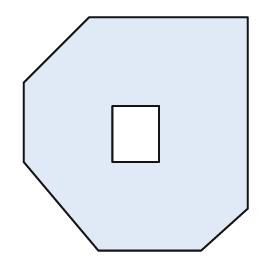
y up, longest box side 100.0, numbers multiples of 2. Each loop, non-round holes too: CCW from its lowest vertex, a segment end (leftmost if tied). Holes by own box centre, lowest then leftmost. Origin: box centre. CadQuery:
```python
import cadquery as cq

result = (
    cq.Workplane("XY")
    .moveTo(-16.0, -50.0)
    .lineTo(28.0, -50.0)
    .lineTo(48.0, -32.0)
    .lineTo(48.0, 50.0)
    .lineTo(-20.0, 50.0)
    .lineTo(-48.0, 22.0)
    .lineTo(-48.0, -12.0)
    .close()
    .moveTo(-10.0, -12.0)
    .lineTo(10.0, -12.0)
    .lineTo(10.0, 12.0)
    .lineTo(-10.0, 12.0)
    .close()
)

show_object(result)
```